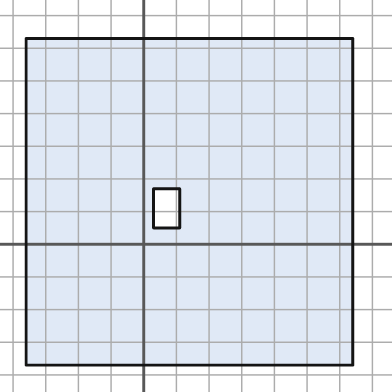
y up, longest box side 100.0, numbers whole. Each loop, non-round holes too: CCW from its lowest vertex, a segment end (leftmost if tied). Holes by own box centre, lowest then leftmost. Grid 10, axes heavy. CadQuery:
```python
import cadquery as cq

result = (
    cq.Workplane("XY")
    .moveTo(-36.0, -37.0)
    .lineTo(64.0, -37.0)
    .lineTo(64.0, 63.0)
    .lineTo(-36.0, 63.0)
    .close()
    .moveTo(3.0, 5.0)
    .lineTo(11.0, 5.0)
    .lineTo(11.0, 17.0)
    .lineTo(3.0, 17.0)
    .close()
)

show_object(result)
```